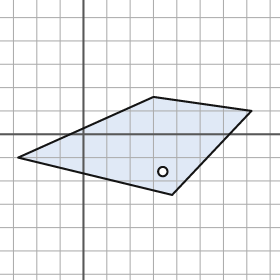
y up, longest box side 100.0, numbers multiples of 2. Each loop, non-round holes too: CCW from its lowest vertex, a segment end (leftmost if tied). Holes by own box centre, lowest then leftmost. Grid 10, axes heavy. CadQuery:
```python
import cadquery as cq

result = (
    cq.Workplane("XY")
    .moveTo(38.0, -26.0)
    .lineTo(72.0, 10.0)
    .lineTo(30.0, 16.0)
    .lineTo(-28.0, -10.0)
    .close()
    .moveTo(34.0, -16.0)
    .circle(2.0)
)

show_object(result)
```